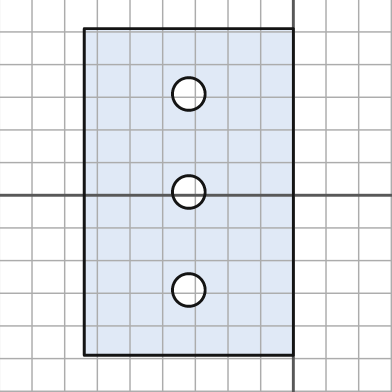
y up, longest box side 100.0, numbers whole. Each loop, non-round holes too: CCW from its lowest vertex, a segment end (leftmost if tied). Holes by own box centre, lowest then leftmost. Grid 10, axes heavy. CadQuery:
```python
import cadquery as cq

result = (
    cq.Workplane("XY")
    .moveTo(-64.0, -49.0)
    .lineTo(0.0, -49.0)
    .lineTo(0.0, 51.0)
    .lineTo(-64.0, 51.0)
    .close()
    .moveTo(-32.0, -29.0)
    .circle(5.0)
    .moveTo(-32.0, 1.0)
    .circle(5.0)
    .moveTo(-32.0, 31.0)
    .circle(5.0)
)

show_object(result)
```